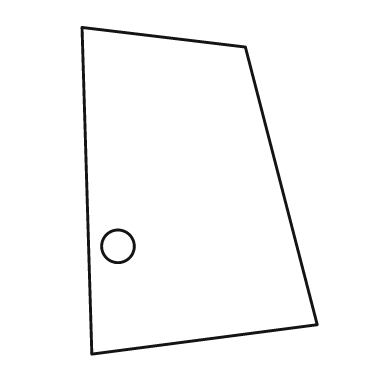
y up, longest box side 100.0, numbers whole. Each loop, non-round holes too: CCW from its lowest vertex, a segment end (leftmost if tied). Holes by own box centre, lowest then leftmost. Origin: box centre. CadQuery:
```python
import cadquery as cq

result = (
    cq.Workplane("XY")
    .moveTo(-33.0, -50.0)
    .lineTo(36.0, -41.0)
    .lineTo(14.0, 44.0)
    .lineTo(-36.0, 50.0)
    .close()
    .moveTo(-25.0, -17.0)
    .circle(5.0)
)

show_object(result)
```